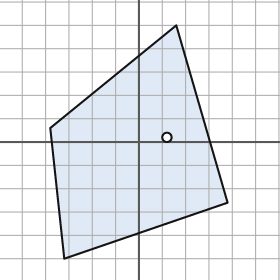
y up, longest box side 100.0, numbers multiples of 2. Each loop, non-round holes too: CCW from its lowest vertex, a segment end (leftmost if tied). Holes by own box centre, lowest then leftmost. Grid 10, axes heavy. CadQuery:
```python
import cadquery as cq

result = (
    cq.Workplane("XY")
    .moveTo(-32.0, -50.0)
    .lineTo(38.0, -26.0)
    .lineTo(16.0, 50.0)
    .lineTo(-38.0, 6.0)
    .close()
    .moveTo(12.0, 2.0)
    .circle(2.0)
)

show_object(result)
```